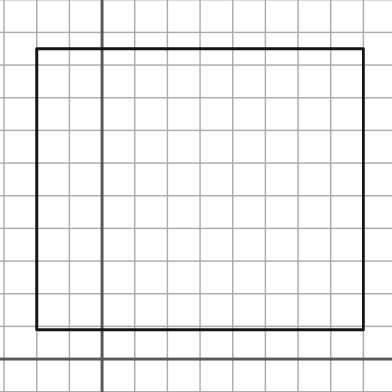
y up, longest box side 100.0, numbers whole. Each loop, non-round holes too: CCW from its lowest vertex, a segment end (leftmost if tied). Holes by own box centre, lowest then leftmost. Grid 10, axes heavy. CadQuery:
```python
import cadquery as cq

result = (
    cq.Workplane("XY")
    .moveTo(-20.0, 9.0)
    .lineTo(80.0, 9.0)
    .lineTo(80.0, 95.0)
    .lineTo(-20.0, 95.0)
    .close()
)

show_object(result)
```